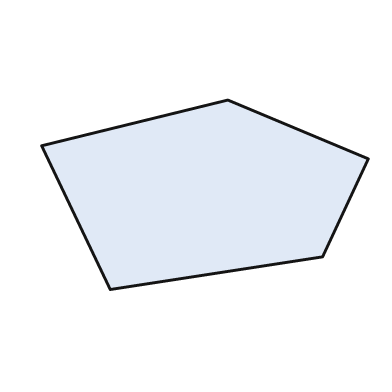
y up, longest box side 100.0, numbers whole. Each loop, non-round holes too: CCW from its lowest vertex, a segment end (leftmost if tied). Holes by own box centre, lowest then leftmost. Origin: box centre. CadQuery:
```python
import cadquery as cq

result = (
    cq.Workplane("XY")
    .moveTo(-29.0, -29.0)
    .lineTo(36.0, -19.0)
    .lineTo(50.0, 11.0)
    .lineTo(7.0, 29.0)
    .lineTo(-50.0, 15.0)
    .close()
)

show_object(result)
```